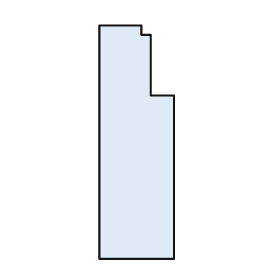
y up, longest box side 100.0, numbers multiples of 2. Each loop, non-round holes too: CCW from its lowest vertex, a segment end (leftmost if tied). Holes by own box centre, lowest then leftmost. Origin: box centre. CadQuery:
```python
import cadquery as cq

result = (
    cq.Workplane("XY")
    .moveTo(-16.0, -50.0)
    .lineTo(16.0, -50.0)
    .lineTo(16.0, 20.0)
    .lineTo(6.0, 20.0)
    .lineTo(6.0, 46.0)
    .lineTo(2.0, 46.0)
    .lineTo(2.0, 50.0)
    .lineTo(-16.0, 50.0)
    .close()
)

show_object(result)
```